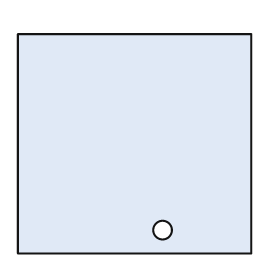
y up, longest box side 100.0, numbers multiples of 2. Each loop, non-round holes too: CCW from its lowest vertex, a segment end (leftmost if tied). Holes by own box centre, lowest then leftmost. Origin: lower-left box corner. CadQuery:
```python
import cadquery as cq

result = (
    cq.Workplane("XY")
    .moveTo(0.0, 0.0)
    .lineTo(100.0, 0.0)
    .lineTo(100.0, 94.0)
    .lineTo(0.0, 94.0)
    .close()
    .moveTo(62.0, 10.0)
    .circle(4.0)
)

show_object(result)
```